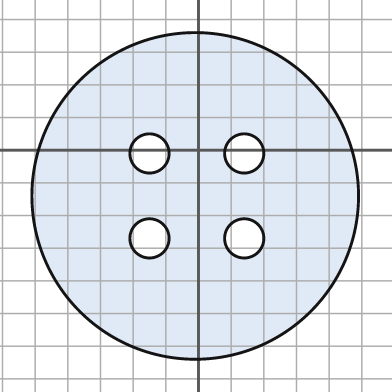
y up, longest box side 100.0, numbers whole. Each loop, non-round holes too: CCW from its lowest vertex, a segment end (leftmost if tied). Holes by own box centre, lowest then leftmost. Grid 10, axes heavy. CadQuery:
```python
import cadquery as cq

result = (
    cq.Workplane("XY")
    .moveTo(-1.0, -14.0)
    .circle(50.0)
    .moveTo(-15.0, -27.0)
    .circle(6.0)
    .moveTo(14.0, -27.0)
    .circle(6.0)
    .moveTo(-15.0, -1.0)
    .circle(6.0)
    .moveTo(14.0, -1.0)
    .circle(6.0)
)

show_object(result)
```